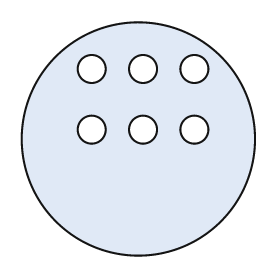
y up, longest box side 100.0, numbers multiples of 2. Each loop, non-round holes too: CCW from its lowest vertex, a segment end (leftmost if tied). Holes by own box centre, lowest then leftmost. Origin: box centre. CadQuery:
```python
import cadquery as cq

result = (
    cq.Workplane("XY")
    .moveTo(0.0, 0.0)
    .circle(50.0)
    .moveTo(-20.0, 4.0)
    .circle(6.0)
    .moveTo(2.0, 4.0)
    .circle(6.0)
    .moveTo(24.0, 4.0)
    .circle(6.0)
    .moveTo(-20.0, 30.0)
    .circle(6.0)
    .moveTo(2.0, 30.0)
    .circle(6.0)
    .moveTo(24.0, 30.0)
    .circle(6.0)
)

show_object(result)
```